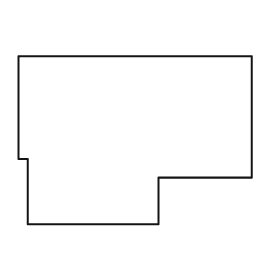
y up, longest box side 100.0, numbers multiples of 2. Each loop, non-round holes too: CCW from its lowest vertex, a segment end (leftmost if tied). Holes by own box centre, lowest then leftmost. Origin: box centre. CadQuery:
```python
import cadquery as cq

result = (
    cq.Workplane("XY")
    .moveTo(-46.0, -36.0)
    .lineTo(10.0, -36.0)
    .lineTo(10.0, -16.0)
    .lineTo(50.0, -16.0)
    .lineTo(50.0, 36.0)
    .lineTo(-50.0, 36.0)
    .lineTo(-50.0, -8.0)
    .lineTo(-46.0, -8.0)
    .close()
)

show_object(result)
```